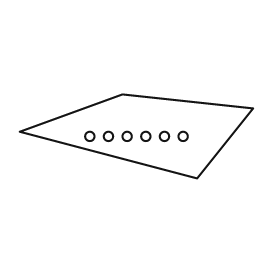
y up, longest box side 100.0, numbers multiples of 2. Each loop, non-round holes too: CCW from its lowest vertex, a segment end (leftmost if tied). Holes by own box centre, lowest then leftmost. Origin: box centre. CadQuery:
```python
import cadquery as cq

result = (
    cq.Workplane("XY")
    .moveTo(26.0, -18.0)
    .lineTo(50.0, 12.0)
    .lineTo(-6.0, 18.0)
    .lineTo(-50.0, 2.0)
    .close()
    .moveTo(-20.0, 0.0)
    .circle(2.0)
    .moveTo(-12.0, 0.0)
    .circle(2.0)
    .moveTo(-4.0, 0.0)
    .circle(2.0)
    .moveTo(4.0, 0.0)
    .circle(2.0)
    .moveTo(12.0, 0.0)
    .circle(2.0)
    .moveTo(20.0, 0.0)
    .circle(2.0)
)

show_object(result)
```